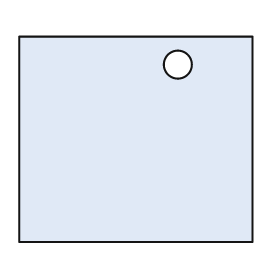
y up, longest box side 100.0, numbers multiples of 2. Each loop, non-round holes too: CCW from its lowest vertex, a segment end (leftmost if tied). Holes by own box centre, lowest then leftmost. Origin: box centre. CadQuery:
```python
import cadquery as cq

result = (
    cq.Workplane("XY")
    .moveTo(-50.0, -44.0)
    .lineTo(50.0, -44.0)
    .lineTo(50.0, 44.0)
    .lineTo(-50.0, 44.0)
    .close()
    .moveTo(18.0, 32.0)
    .circle(6.0)
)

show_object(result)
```